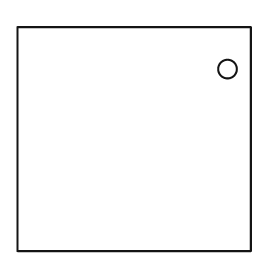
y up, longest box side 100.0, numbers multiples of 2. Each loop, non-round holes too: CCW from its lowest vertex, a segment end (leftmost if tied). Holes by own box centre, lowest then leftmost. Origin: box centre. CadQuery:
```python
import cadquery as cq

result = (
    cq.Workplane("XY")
    .moveTo(-50.0, -48.0)
    .lineTo(50.0, -48.0)
    .lineTo(50.0, 48.0)
    .lineTo(-50.0, 48.0)
    .close()
    .moveTo(40.0, 30.0)
    .circle(4.0)
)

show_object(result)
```